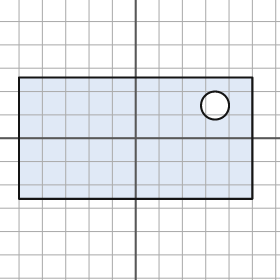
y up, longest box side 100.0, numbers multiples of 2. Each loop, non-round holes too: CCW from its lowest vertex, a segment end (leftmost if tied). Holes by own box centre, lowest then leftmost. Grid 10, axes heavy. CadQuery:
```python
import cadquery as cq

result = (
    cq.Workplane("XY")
    .moveTo(-50.0, -26.0)
    .lineTo(50.0, -26.0)
    .lineTo(50.0, 26.0)
    .lineTo(-50.0, 26.0)
    .close()
    .moveTo(34.0, 14.0)
    .circle(6.0)
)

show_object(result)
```